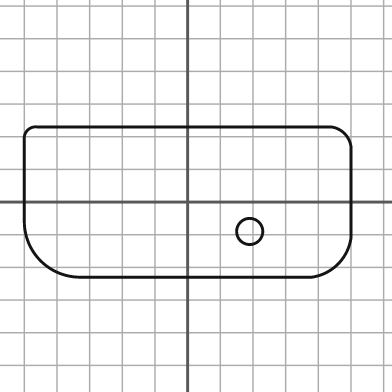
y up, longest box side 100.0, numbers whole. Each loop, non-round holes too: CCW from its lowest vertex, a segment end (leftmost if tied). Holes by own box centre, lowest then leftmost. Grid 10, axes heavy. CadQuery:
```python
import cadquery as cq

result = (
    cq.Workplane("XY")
    .moveTo(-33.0, -23.0)
    .lineTo(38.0, -23.0)
    .threePointArc((46.0, -19.0), (50.0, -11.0))
    .lineTo(50.0, 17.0)
    .threePointArc((48.0, 21.0), (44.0, 23.0))
    .lineTo(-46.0, 23.0)
    .threePointArc((-49.0, 22.0), (-50.0, 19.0))
    .lineTo(-50.0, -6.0)
    .threePointArc((-45.0, -18.0), (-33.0, -23.0))
    .close()
    .moveTo(19.0, -9.0)
    .circle(4.0)
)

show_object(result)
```